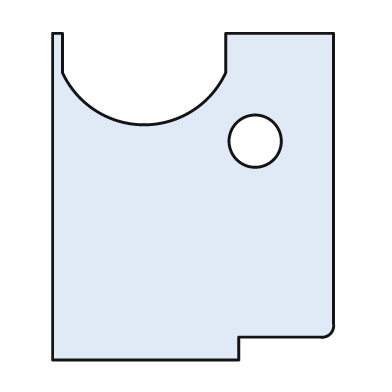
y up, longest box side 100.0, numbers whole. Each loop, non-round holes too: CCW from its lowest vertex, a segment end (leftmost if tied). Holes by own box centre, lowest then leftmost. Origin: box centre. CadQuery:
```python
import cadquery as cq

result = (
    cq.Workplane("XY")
    .moveTo(-43.0, -50.0)
    .lineTo(14.0, -50.0)
    .lineTo(14.0, -43.0)
    .lineTo(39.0, -43.0)
    .threePointArc((42.0, -42.0), (43.0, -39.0))
    .lineTo(43.0, 50.0)
    .lineTo(10.0, 50.0)
    .lineTo(10.0, 38.0)
    .threePointArc((-15.0, 22.0), (-40.0, 38.0))
    .lineTo(-40.0, 50.0)
    .lineTo(-43.0, 50.0)
    .close()
    .moveTo(19.0, 17.0)
    .circle(8.0)
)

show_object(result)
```